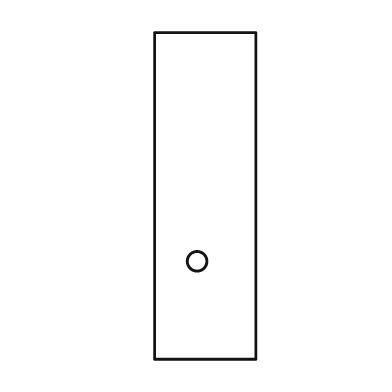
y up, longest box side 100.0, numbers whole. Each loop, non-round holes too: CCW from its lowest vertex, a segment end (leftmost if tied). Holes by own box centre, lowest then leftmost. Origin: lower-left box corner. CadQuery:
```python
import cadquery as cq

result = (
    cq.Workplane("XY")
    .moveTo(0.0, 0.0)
    .lineTo(31.0, 0.0)
    .lineTo(31.0, 100.0)
    .lineTo(0.0, 100.0)
    .close()
    .moveTo(13.0, 30.0)
    .circle(3.0)
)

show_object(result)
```